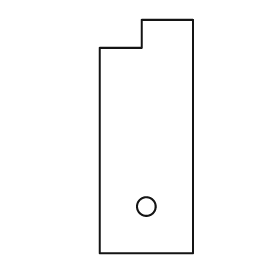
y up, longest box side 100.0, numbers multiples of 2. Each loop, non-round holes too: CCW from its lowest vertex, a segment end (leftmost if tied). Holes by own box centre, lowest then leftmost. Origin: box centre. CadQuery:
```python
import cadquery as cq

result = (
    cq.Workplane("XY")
    .moveTo(-20.0, -50.0)
    .lineTo(20.0, -50.0)
    .lineTo(20.0, 50.0)
    .lineTo(-2.0, 50.0)
    .lineTo(-2.0, 38.0)
    .lineTo(-20.0, 38.0)
    .close()
    .moveTo(0.0, -30.0)
    .circle(4.0)
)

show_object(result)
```